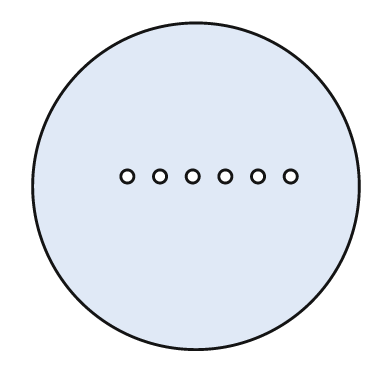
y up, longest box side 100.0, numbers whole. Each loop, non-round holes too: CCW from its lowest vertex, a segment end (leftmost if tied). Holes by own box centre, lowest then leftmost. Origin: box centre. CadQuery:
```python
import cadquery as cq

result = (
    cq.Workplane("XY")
    .moveTo(0.0, 0.0)
    .circle(50.0)
    .moveTo(-21.0, 3.0)
    .circle(2.0)
    .moveTo(-11.0, 3.0)
    .circle(2.0)
    .moveTo(-1.0, 3.0)
    .circle(2.0)
    .moveTo(9.0, 3.0)
    .circle(2.0)
    .moveTo(19.0, 3.0)
    .circle(2.0)
    .moveTo(29.0, 3.0)
    .circle(2.0)
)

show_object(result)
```